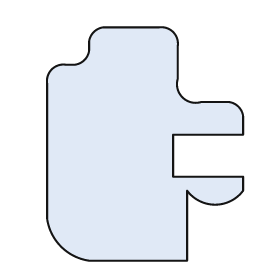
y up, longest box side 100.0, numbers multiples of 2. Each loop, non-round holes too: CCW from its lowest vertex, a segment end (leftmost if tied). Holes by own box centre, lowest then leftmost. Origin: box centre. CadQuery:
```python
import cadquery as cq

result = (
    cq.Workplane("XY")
    .moveTo(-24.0, -50.0)
    .lineTo(18.0, -50.0)
    .lineTo(18.0, -20.0)
    .threePointArc((30.0, -26.0), (42.0, -20.0))
    .lineTo(42.0, -14.0)
    .lineTo(12.0, -14.0)
    .lineTo(12.0, 4.0)
    .lineTo(42.0, 4.0)
    .lineTo(42.0, 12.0)
    .threePointArc((40.0, 16.0), (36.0, 18.0))
    .lineTo(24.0, 18.0)
    .threePointArc((16.0, 20.0), (14.0, 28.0))
    .lineTo(14.0, 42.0)
    .threePointArc((12.0, 48.0), (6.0, 50.0))
    .lineTo(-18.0, 50.0)
    .threePointArc((-22.0, 48.0), (-24.0, 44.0))
    .lineTo(-24.0, 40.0)
    .threePointArc((-26.0, 36.0), (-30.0, 34.0))
    .lineTo(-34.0, 34.0)
    .threePointArc((-40.0, 32.0), (-42.0, 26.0))
    .lineTo(-42.0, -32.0)
    .threePointArc((-36.0, -44.0), (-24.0, -50.0))
    .close()
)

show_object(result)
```